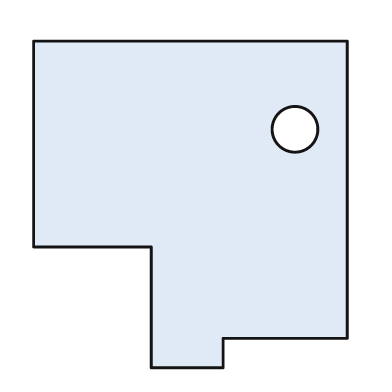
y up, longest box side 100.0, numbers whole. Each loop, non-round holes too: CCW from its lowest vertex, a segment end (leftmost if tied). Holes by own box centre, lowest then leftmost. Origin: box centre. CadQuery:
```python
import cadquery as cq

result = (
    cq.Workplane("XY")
    .moveTo(-12.0, -50.0)
    .lineTo(10.0, -50.0)
    .lineTo(10.0, -41.0)
    .lineTo(48.0, -41.0)
    .lineTo(48.0, 50.0)
    .lineTo(-48.0, 50.0)
    .lineTo(-48.0, -13.0)
    .lineTo(-12.0, -13.0)
    .close()
    .moveTo(32.0, 23.0)
    .circle(7.0)
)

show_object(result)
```